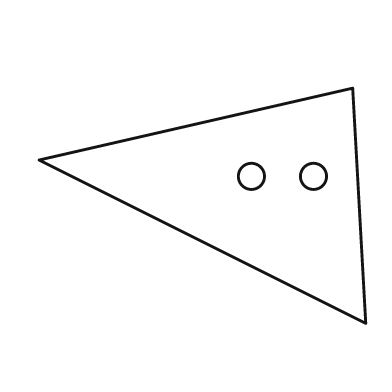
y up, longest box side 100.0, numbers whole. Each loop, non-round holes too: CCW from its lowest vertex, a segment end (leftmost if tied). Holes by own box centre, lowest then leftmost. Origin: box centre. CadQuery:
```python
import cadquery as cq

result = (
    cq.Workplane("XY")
    .moveTo(50.0, -36.0)
    .lineTo(46.0, 36.0)
    .lineTo(-50.0, 14.0)
    .close()
    .moveTo(15.0, 9.0)
    .circle(4.0)
    .moveTo(34.0, 9.0)
    .circle(4.0)
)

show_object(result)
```